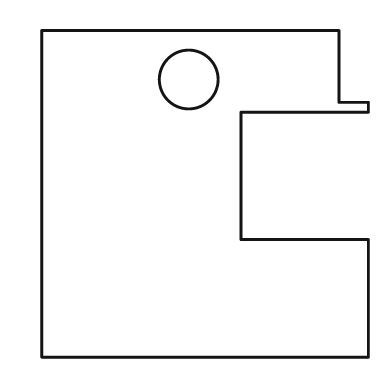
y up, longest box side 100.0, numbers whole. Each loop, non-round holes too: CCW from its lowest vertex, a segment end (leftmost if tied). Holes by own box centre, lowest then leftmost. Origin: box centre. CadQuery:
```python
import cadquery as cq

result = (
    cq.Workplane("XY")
    .moveTo(-50.0, -50.0)
    .lineTo(50.0, -50.0)
    .lineTo(50.0, -14.0)
    .lineTo(11.0, -14.0)
    .lineTo(11.0, 25.0)
    .lineTo(50.0, 25.0)
    .lineTo(50.0, 28.0)
    .lineTo(41.0, 28.0)
    .lineTo(41.0, 50.0)
    .lineTo(-50.0, 50.0)
    .close()
    .moveTo(-5.0, 35.0)
    .circle(9.0)
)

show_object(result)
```